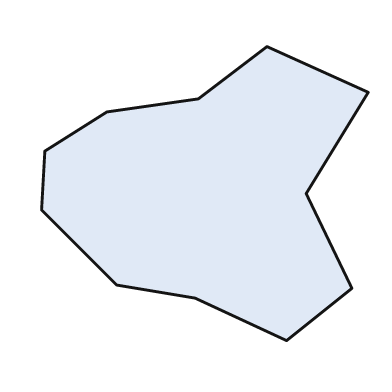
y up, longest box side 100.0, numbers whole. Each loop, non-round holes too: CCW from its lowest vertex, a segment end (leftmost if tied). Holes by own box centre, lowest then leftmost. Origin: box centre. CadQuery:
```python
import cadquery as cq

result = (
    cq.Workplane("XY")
    .moveTo(25.0, -45.0)
    .lineTo(45.0, -29.0)
    .lineTo(31.0, 0.0)
    .lineTo(50.0, 31.0)
    .lineTo(19.0, 45.0)
    .lineTo(-2.0, 29.0)
    .lineTo(-30.0, 25.0)
    .lineTo(-49.0, 13.0)
    .lineTo(-50.0, -5.0)
    .lineTo(-27.0, -28.0)
    .lineTo(-3.0, -32.0)
    .close()
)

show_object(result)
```